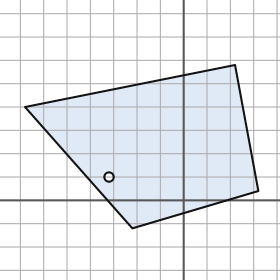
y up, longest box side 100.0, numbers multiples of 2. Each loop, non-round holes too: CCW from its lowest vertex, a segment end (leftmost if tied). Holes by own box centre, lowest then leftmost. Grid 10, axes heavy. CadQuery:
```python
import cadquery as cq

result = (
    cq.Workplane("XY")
    .moveTo(-22.0, -12.0)
    .lineTo(32.0, 4.0)
    .lineTo(22.0, 58.0)
    .lineTo(-68.0, 40.0)
    .close()
    .moveTo(-32.0, 10.0)
    .circle(2.0)
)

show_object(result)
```